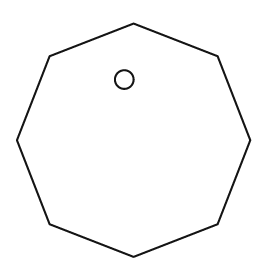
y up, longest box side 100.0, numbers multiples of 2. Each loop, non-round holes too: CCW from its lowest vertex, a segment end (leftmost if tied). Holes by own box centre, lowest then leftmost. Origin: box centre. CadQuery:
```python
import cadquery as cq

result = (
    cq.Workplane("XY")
    .moveTo(0.0, -50.0)
    .lineTo(36.0, -36.0)
    .lineTo(50.0, 0.0)
    .lineTo(36.0, 36.0)
    .lineTo(0.0, 50.0)
    .lineTo(-36.0, 36.0)
    .lineTo(-50.0, 0.0)
    .lineTo(-36.0, -36.0)
    .close()
    .moveTo(-4.0, 26.0)
    .circle(4.0)
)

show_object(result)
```